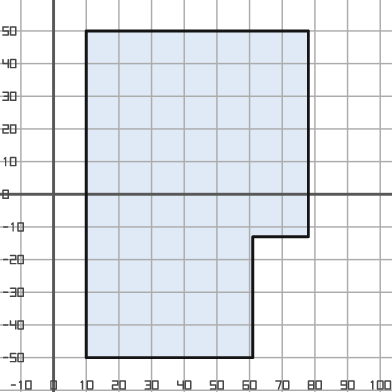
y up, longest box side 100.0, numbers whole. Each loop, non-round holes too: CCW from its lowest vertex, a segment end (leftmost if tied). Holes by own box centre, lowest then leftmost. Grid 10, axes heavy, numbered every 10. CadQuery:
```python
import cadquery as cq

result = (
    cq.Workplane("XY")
    .moveTo(10.0, -50.0)
    .lineTo(61.0, -50.0)
    .lineTo(61.0, -13.0)
    .lineTo(78.0, -13.0)
    .lineTo(78.0, 50.0)
    .lineTo(10.0, 50.0)
    .close()
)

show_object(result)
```